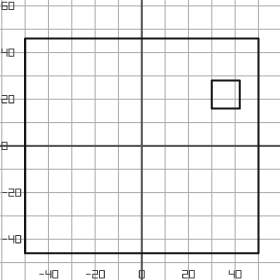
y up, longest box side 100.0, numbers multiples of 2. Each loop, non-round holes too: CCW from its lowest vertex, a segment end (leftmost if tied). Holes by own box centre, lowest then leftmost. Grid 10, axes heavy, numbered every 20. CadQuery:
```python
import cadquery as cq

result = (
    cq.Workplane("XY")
    .moveTo(-50.0, -46.0)
    .lineTo(50.0, -46.0)
    .lineTo(50.0, 46.0)
    .lineTo(-50.0, 46.0)
    .close()
    .moveTo(30.0, 16.0)
    .lineTo(42.0, 16.0)
    .lineTo(42.0, 28.0)
    .lineTo(30.0, 28.0)
    .close()
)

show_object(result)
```